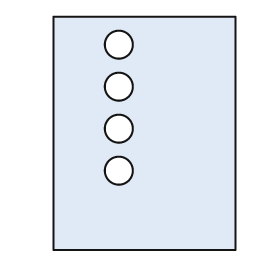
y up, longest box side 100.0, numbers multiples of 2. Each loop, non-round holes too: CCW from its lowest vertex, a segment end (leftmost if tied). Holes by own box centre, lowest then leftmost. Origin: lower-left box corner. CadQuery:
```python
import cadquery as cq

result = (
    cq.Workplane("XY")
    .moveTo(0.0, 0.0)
    .lineTo(78.0, 0.0)
    .lineTo(78.0, 100.0)
    .lineTo(0.0, 100.0)
    .close()
    .moveTo(28.0, 34.0)
    .circle(6.0)
    .moveTo(28.0, 52.0)
    .circle(6.0)
    .moveTo(28.0, 70.0)
    .circle(6.0)
    .moveTo(28.0, 88.0)
    .circle(6.0)
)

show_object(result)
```